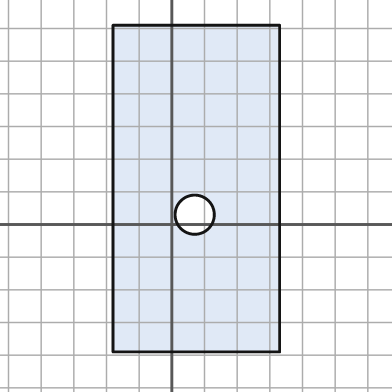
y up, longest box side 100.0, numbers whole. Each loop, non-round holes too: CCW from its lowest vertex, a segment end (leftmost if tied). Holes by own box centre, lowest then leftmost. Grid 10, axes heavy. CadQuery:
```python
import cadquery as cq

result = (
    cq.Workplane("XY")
    .moveTo(-18.0, -39.0)
    .lineTo(33.0, -39.0)
    .lineTo(33.0, 61.0)
    .lineTo(-18.0, 61.0)
    .close()
    .moveTo(7.0, 3.0)
    .circle(6.0)
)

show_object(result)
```